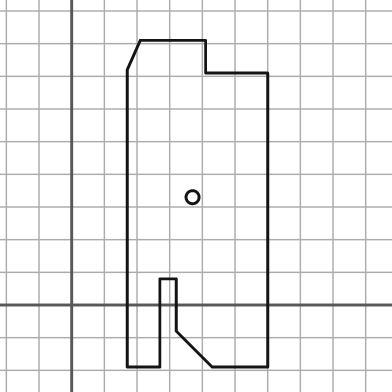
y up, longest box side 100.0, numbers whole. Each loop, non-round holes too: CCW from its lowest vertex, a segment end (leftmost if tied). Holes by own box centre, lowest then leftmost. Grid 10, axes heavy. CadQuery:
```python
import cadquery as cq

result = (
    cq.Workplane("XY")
    .moveTo(17.0, -19.0)
    .lineTo(27.0, -19.0)
    .lineTo(27.0, 8.0)
    .lineTo(32.0, 8.0)
    .lineTo(32.0, -8.0)
    .lineTo(43.0, -19.0)
    .lineTo(60.0, -19.0)
    .lineTo(60.0, 71.0)
    .lineTo(41.0, 71.0)
    .lineTo(41.0, 81.0)
    .lineTo(21.0, 81.0)
    .lineTo(17.0, 72.0)
    .close()
    .moveTo(37.0, 33.0)
    .circle(2.0)
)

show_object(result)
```